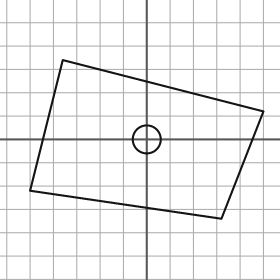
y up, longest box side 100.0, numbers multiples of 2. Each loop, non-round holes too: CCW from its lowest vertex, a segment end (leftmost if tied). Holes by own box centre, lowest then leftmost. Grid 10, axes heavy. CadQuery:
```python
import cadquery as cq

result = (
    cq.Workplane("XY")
    .moveTo(32.0, -34.0)
    .lineTo(50.0, 12.0)
    .lineTo(-36.0, 34.0)
    .lineTo(-50.0, -22.0)
    .close()
    .moveTo(0.0, 0.0)
    .circle(6.0)
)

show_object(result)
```